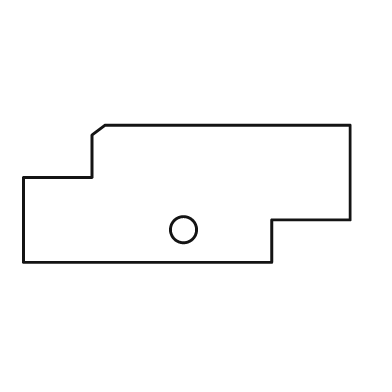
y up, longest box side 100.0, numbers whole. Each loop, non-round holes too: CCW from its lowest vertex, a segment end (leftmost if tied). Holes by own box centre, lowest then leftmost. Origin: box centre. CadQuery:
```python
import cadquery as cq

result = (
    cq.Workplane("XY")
    .moveTo(-50.0, -21.0)
    .lineTo(26.0, -21.0)
    .lineTo(26.0, -8.0)
    .lineTo(50.0, -8.0)
    .lineTo(50.0, 21.0)
    .lineTo(-25.0, 21.0)
    .lineTo(-29.0, 18.0)
    .lineTo(-29.0, 5.0)
    .lineTo(-50.0, 5.0)
    .close()
    .moveTo(-1.0, -11.0)
    .circle(4.0)
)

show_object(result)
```